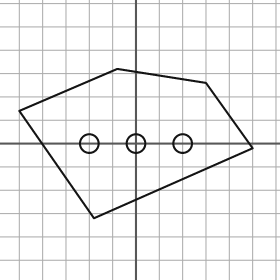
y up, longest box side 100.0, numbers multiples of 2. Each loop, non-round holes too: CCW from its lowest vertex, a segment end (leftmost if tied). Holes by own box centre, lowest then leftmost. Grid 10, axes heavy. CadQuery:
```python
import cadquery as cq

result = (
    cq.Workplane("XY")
    .moveTo(-18.0, -32.0)
    .lineTo(50.0, -2.0)
    .lineTo(30.0, 26.0)
    .lineTo(-8.0, 32.0)
    .lineTo(-50.0, 14.0)
    .close()
    .moveTo(-20.0, 0.0)
    .circle(4.0)
    .moveTo(0.0, 0.0)
    .circle(4.0)
    .moveTo(20.0, 0.0)
    .circle(4.0)
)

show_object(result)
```